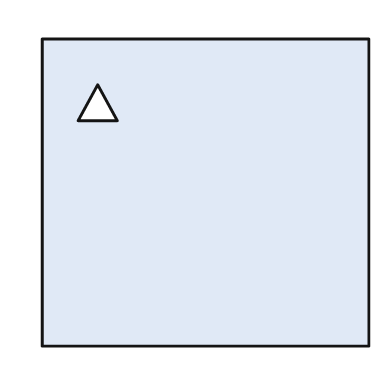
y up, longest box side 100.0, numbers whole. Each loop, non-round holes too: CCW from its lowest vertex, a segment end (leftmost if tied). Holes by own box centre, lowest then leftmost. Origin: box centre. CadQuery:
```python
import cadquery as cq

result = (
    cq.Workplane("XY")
    .moveTo(-50.0, -47.0)
    .lineTo(50.0, -47.0)
    .lineTo(50.0, 47.0)
    .lineTo(-50.0, 47.0)
    .close()
    .moveTo(-39.0, 22.0)
    .lineTo(-27.0, 22.0)
    .lineTo(-33.0, 33.0)
    .close()
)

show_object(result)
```